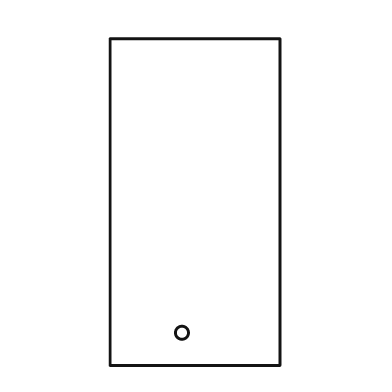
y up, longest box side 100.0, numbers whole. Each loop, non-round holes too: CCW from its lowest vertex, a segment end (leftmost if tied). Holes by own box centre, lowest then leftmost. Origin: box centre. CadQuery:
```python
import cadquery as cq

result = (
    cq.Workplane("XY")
    .moveTo(-26.0, -50.0)
    .lineTo(26.0, -50.0)
    .lineTo(26.0, 50.0)
    .lineTo(-26.0, 50.0)
    .close()
    .moveTo(-4.0, -40.0)
    .circle(2.0)
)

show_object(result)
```